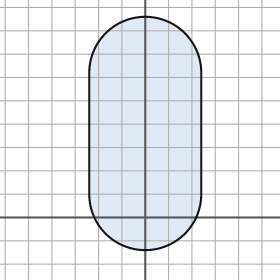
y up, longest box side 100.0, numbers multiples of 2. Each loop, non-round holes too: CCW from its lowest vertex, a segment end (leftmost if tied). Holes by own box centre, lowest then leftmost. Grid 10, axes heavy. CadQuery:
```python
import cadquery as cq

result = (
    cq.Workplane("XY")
    .moveTo(-24.0, 10.0)
    .threePointArc((0.0, -14.0), (24.0, 10.0))
    .lineTo(24.0, 62.0)
    .threePointArc((0.0, 86.0), (-24.0, 62.0))
    .close()
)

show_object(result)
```